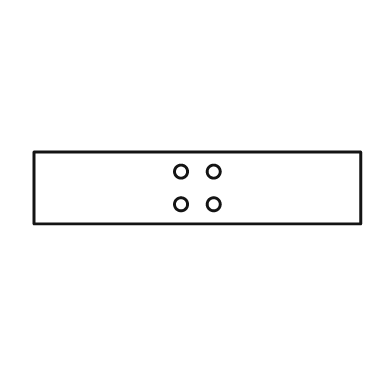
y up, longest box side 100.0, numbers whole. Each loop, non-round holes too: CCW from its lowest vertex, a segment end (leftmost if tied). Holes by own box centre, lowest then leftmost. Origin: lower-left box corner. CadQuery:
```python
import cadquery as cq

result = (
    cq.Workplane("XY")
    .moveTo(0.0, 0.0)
    .lineTo(100.0, 0.0)
    .lineTo(100.0, 22.0)
    .lineTo(0.0, 22.0)
    .close()
    .moveTo(45.0, 6.0)
    .circle(2.0)
    .moveTo(55.0, 6.0)
    .circle(2.0)
    .moveTo(45.0, 16.0)
    .circle(2.0)
    .moveTo(55.0, 16.0)
    .circle(2.0)
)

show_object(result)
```